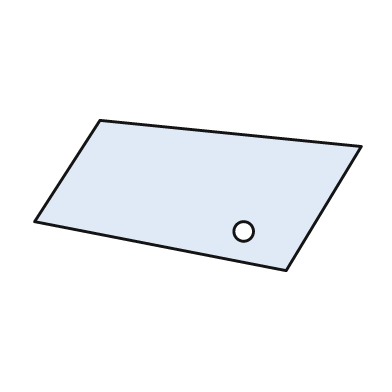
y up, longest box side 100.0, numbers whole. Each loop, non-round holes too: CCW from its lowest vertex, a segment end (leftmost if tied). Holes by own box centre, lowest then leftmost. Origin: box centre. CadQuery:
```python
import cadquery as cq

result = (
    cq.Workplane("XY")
    .moveTo(27.0, -23.0)
    .lineTo(50.0, 15.0)
    .lineTo(-30.0, 23.0)
    .lineTo(-50.0, -8.0)
    .close()
    .moveTo(14.0, -11.0)
    .circle(3.0)
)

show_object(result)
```